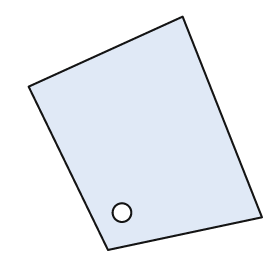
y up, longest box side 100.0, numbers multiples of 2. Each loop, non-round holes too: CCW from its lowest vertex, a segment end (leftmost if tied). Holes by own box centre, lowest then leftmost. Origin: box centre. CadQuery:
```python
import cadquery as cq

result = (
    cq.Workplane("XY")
    .moveTo(-16.0, -50.0)
    .lineTo(50.0, -36.0)
    .lineTo(16.0, 50.0)
    .lineTo(-50.0, 20.0)
    .close()
    .moveTo(-10.0, -34.0)
    .circle(4.0)
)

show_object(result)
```